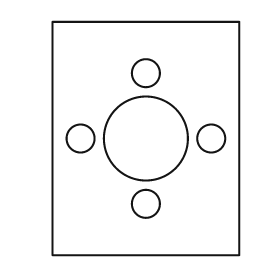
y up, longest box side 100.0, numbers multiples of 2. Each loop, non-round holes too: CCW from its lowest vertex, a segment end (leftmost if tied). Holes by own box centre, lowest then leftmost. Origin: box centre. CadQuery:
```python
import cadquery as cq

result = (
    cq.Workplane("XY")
    .moveTo(-40.0, -50.0)
    .lineTo(40.0, -50.0)
    .lineTo(40.0, 50.0)
    .lineTo(-40.0, 50.0)
    .close()
    .moveTo(0.0, -28.0)
    .circle(6.0)
    .moveTo(-28.0, 0.0)
    .circle(6.0)
    .moveTo(0.0, 0.0)
    .circle(18.0)
    .moveTo(28.0, 0.0)
    .circle(6.0)
    .moveTo(0.0, 28.0)
    .circle(6.0)
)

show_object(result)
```